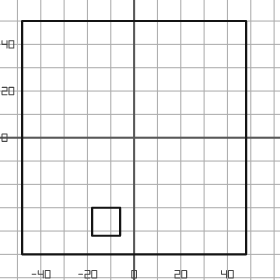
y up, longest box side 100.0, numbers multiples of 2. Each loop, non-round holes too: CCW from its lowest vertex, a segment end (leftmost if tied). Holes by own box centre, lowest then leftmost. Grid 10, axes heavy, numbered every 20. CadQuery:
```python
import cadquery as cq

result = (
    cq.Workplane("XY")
    .moveTo(-48.0, -50.0)
    .lineTo(48.0, -50.0)
    .lineTo(48.0, 50.0)
    .lineTo(-48.0, 50.0)
    .close()
    .moveTo(-18.0, -42.0)
    .lineTo(-6.0, -42.0)
    .lineTo(-6.0, -30.0)
    .lineTo(-18.0, -30.0)
    .close()
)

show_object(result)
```